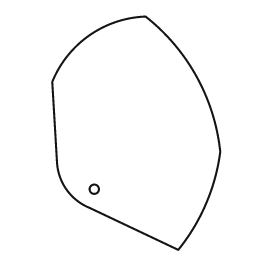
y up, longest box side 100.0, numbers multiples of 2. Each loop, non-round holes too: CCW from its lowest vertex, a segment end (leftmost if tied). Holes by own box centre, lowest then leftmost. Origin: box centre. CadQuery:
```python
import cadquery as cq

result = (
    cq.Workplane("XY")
    .moveTo(18.0, -50.0)
    .threePointArc((30.0, -30.0), (36.0, -8.0))
    .threePointArc((26.0, 24.0), (4.0, 50.0))
    .threePointArc((-20.0, 42.0), (-36.0, 22.0))
    .lineTo(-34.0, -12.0)
    .threePointArc((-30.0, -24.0), (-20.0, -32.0))
    .close()
    .moveTo(-18.0, -24.0)
    .circle(2.0)
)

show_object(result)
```